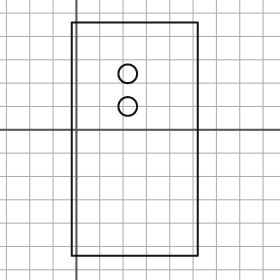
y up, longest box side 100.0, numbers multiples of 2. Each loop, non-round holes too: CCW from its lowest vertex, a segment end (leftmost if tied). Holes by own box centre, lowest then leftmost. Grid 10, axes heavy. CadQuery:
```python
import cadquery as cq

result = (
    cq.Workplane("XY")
    .moveTo(-2.0, -54.0)
    .lineTo(52.0, -54.0)
    .lineTo(52.0, 46.0)
    .lineTo(-2.0, 46.0)
    .close()
    .moveTo(22.0, 10.0)
    .circle(4.0)
    .moveTo(22.0, 24.0)
    .circle(4.0)
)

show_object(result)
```